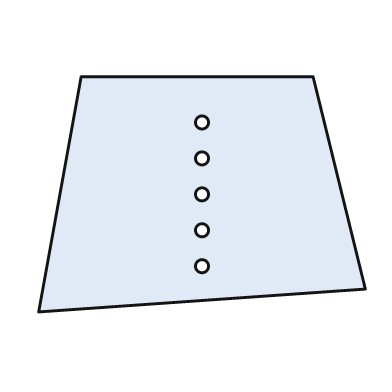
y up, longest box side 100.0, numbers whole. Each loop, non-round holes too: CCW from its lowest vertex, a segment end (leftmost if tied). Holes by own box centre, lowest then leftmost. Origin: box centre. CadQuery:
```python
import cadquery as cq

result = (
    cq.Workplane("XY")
    .moveTo(-50.0, -36.0)
    .lineTo(50.0, -29.0)
    .lineTo(34.0, 36.0)
    .lineTo(-37.0, 36.0)
    .close()
    .moveTo(0.0, -22.0)
    .circle(2.0)
    .moveTo(0.0, -11.0)
    .circle(2.0)
    .moveTo(0.0, 0.0)
    .circle(2.0)
    .moveTo(0.0, 11.0)
    .circle(2.0)
    .moveTo(0.0, 22.0)
    .circle(2.0)
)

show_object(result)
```